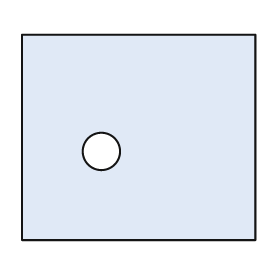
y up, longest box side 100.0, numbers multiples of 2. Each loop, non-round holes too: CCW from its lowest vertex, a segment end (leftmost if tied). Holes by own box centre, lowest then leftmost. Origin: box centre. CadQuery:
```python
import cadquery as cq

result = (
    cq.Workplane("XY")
    .moveTo(-50.0, -44.0)
    .lineTo(50.0, -44.0)
    .lineTo(50.0, 44.0)
    .lineTo(-50.0, 44.0)
    .close()
    .moveTo(-16.0, -6.0)
    .circle(8.0)
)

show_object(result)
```